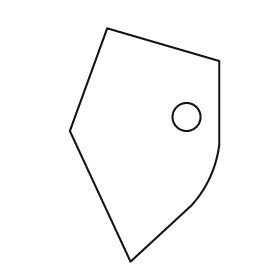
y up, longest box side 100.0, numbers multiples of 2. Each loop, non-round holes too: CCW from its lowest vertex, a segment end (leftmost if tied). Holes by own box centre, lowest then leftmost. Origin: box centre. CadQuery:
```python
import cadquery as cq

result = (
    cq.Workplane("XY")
    .moveTo(-6.0, -50.0)
    .lineTo(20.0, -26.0)
    .threePointArc((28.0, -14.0), (32.0, 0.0))
    .lineTo(32.0, 36.0)
    .lineTo(-16.0, 50.0)
    .lineTo(-32.0, 6.0)
    .close()
    .moveTo(18.0, 12.0)
    .circle(6.0)
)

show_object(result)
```